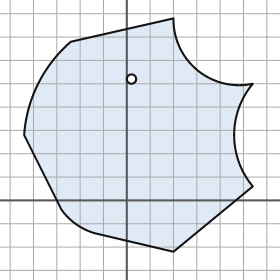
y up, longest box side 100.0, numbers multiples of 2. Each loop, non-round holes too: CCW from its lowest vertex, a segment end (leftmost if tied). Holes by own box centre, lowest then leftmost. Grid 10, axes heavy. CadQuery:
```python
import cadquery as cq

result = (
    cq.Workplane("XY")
    .moveTo(20.0, -22.0)
    .lineTo(54.0, 6.0)
    .threePointArc((46.0, 28.0), (54.0, 50.0))
    .threePointArc((30.0, 56.0), (20.0, 78.0))
    .lineTo(-24.0, 68.0)
    .threePointArc((-38.0, 50.0), (-44.0, 28.0))
    .lineTo(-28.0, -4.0)
    .threePointArc((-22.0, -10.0), (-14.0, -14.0))
    .close()
    .moveTo(2.0, 52.0)
    .circle(2.0)
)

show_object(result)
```